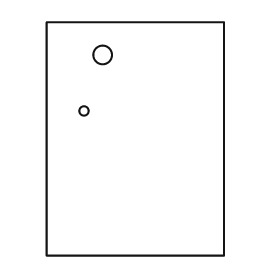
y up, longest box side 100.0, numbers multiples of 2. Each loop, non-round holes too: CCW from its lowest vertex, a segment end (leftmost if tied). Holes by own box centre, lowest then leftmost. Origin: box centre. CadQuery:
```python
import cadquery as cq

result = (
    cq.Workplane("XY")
    .moveTo(-38.0, -50.0)
    .lineTo(38.0, -50.0)
    .lineTo(38.0, 50.0)
    .lineTo(-38.0, 50.0)
    .close()
    .moveTo(-22.0, 12.0)
    .circle(2.0)
    .moveTo(-14.0, 36.0)
    .circle(4.0)
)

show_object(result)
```